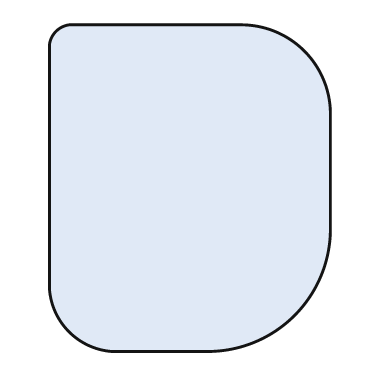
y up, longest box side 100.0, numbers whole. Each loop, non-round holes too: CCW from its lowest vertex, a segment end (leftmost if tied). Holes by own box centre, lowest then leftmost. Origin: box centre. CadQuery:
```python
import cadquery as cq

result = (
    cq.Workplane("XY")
    .moveTo(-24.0, -50.0)
    .lineTo(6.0, -50.0)
    .threePointArc((32.0, -39.0), (43.0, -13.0))
    .lineTo(43.0, 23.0)
    .threePointArc((35.0, 42.0), (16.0, 50.0))
    .lineTo(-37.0, 50.0)
    .threePointArc((-41.0, 48.0), (-43.0, 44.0))
    .lineTo(-43.0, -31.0)
    .threePointArc((-37.0, -44.0), (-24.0, -50.0))
    .close()
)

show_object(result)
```